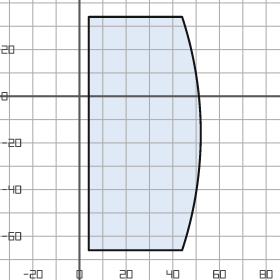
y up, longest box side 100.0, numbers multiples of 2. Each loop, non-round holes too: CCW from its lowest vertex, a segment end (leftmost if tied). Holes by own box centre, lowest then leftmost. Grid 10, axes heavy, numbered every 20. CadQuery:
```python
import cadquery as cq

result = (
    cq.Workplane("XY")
    .moveTo(4.0, -66.0)
    .lineTo(44.0, -66.0)
    .threePointArc((52.0, -16.0), (44.0, 34.0))
    .lineTo(4.0, 34.0)
    .close()
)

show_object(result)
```